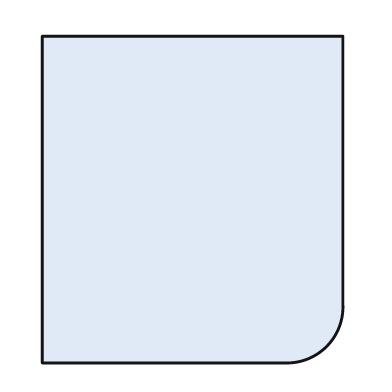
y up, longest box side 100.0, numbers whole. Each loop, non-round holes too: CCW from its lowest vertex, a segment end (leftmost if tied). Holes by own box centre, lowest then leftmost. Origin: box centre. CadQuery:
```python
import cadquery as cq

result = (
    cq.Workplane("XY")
    .moveTo(-46.0, -50.0)
    .lineTo(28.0, -50.0)
    .threePointArc((41.0, -45.0), (46.0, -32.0))
    .lineTo(46.0, 50.0)
    .lineTo(-46.0, 50.0)
    .close()
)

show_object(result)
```